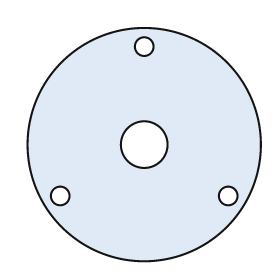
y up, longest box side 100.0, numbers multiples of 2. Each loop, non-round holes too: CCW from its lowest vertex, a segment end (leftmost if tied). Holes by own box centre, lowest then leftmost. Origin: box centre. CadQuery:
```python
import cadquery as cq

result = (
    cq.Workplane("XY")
    .moveTo(0.0, 0.0)
    .circle(50.0)
    .moveTo(-36.0, -22.0)
    .circle(4.0)
    .moveTo(36.0, -22.0)
    .circle(4.0)
    .moveTo(0.0, 0.0)
    .circle(10.0)
    .moveTo(0.0, 42.0)
    .circle(4.0)
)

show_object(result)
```